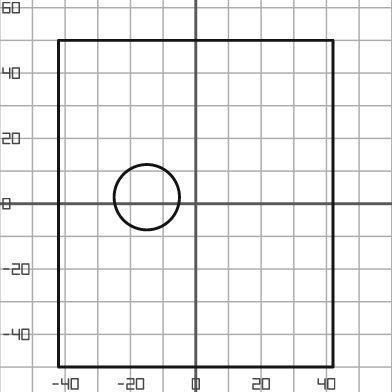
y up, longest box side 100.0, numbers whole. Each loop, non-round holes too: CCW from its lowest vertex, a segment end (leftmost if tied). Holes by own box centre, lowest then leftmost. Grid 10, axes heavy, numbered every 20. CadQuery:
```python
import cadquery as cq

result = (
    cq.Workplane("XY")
    .moveTo(-42.0, -50.0)
    .lineTo(42.0, -50.0)
    .lineTo(42.0, 50.0)
    .lineTo(-42.0, 50.0)
    .close()
    .moveTo(-15.0, 2.0)
    .circle(10.0)
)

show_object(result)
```